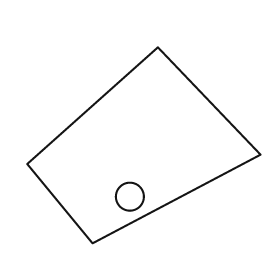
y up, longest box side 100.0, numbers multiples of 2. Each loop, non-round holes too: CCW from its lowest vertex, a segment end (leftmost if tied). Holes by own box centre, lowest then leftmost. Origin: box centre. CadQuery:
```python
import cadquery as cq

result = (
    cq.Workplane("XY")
    .moveTo(-22.0, -42.0)
    .lineTo(50.0, -4.0)
    .lineTo(6.0, 42.0)
    .lineTo(-50.0, -8.0)
    .close()
    .moveTo(-6.0, -22.0)
    .circle(6.0)
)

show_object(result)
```